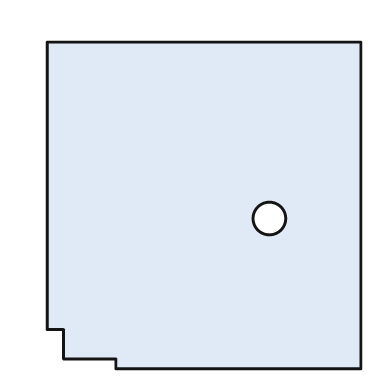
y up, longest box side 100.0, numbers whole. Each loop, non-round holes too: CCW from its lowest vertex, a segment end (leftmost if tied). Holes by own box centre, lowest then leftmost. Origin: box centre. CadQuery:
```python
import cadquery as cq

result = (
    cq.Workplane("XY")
    .moveTo(-27.0, -50.0)
    .lineTo(48.0, -50.0)
    .lineTo(48.0, 50.0)
    .lineTo(-48.0, 50.0)
    .lineTo(-48.0, -38.0)
    .lineTo(-43.0, -38.0)
    .lineTo(-43.0, -47.0)
    .lineTo(-27.0, -47.0)
    .close()
    .moveTo(20.0, -4.0)
    .circle(5.0)
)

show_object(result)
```